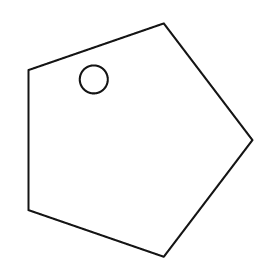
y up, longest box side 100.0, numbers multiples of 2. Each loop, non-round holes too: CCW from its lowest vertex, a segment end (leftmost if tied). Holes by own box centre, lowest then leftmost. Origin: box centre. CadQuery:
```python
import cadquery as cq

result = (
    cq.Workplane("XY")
    .moveTo(10.0, -50.0)
    .lineTo(48.0, 0.0)
    .lineTo(10.0, 50.0)
    .lineTo(-48.0, 30.0)
    .lineTo(-48.0, -30.0)
    .close()
    .moveTo(-20.0, 26.0)
    .circle(6.0)
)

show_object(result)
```